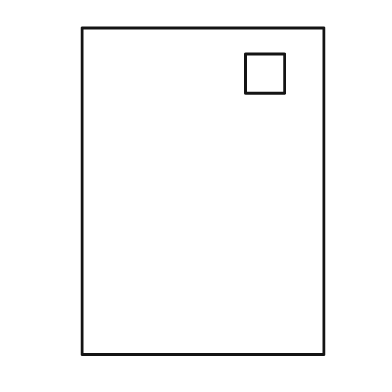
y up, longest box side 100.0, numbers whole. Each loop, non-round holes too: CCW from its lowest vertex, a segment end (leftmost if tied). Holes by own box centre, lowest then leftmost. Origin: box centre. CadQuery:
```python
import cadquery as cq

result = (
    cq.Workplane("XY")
    .moveTo(-37.0, -50.0)
    .lineTo(37.0, -50.0)
    .lineTo(37.0, 50.0)
    .lineTo(-37.0, 50.0)
    .close()
    .moveTo(13.0, 30.0)
    .lineTo(25.0, 30.0)
    .lineTo(25.0, 42.0)
    .lineTo(13.0, 42.0)
    .close()
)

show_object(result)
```